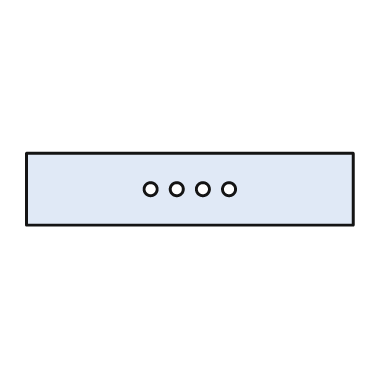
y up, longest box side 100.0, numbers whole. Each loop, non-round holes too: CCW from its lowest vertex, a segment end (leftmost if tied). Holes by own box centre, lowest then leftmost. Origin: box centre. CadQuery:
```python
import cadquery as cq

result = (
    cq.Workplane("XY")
    .moveTo(-50.0, -11.0)
    .lineTo(50.0, -11.0)
    .lineTo(50.0, 11.0)
    .lineTo(-50.0, 11.0)
    .close()
    .moveTo(-12.0, 0.0)
    .circle(2.0)
    .moveTo(-4.0, 0.0)
    .circle(2.0)
    .moveTo(4.0, 0.0)
    .circle(2.0)
    .moveTo(12.0, 0.0)
    .circle(2.0)
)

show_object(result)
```